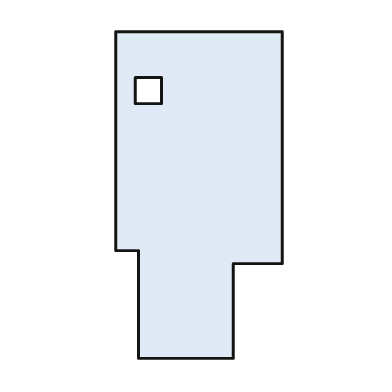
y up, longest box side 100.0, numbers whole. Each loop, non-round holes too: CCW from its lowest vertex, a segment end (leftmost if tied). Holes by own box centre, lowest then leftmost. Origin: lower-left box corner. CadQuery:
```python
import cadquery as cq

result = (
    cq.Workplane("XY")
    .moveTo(7.0, 0.0)
    .lineTo(36.0, 0.0)
    .lineTo(36.0, 29.0)
    .lineTo(51.0, 29.0)
    .lineTo(51.0, 100.0)
    .lineTo(0.0, 100.0)
    .lineTo(0.0, 33.0)
    .lineTo(7.0, 33.0)
    .close()
    .moveTo(6.0, 78.0)
    .lineTo(14.0, 78.0)
    .lineTo(14.0, 86.0)
    .lineTo(6.0, 86.0)
    .close()
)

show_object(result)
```